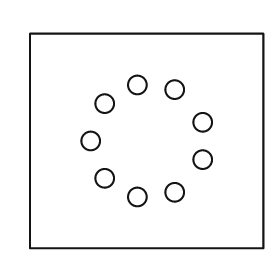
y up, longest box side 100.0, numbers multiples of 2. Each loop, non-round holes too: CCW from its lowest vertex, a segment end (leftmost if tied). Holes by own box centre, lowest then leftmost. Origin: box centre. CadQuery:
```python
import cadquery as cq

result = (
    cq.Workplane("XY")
    .moveTo(-50.0, -46.0)
    .lineTo(50.0, -46.0)
    .lineTo(50.0, 46.0)
    .lineTo(-50.0, 46.0)
    .close()
    .moveTo(-4.0, -24.0)
    .circle(4.0)
    .moveTo(12.0, -22.0)
    .circle(4.0)
    .moveTo(-18.0, -16.0)
    .circle(4.0)
    .moveTo(24.0, -8.0)
    .circle(4.0)
    .moveTo(-24.0, 0.0)
    .circle(4.0)
    .moveTo(24.0, 8.0)
    .circle(4.0)
    .moveTo(-18.0, 16.0)
    .circle(4.0)
    .moveTo(12.0, 22.0)
    .circle(4.0)
    .moveTo(-4.0, 24.0)
    .circle(4.0)
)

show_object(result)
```